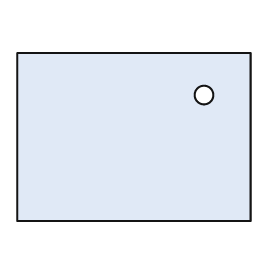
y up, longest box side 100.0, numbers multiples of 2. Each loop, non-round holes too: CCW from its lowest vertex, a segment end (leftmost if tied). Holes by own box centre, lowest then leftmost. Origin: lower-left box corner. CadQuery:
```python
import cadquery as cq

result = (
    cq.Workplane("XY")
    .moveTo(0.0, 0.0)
    .lineTo(100.0, 0.0)
    .lineTo(100.0, 72.0)
    .lineTo(0.0, 72.0)
    .close()
    .moveTo(80.0, 54.0)
    .circle(4.0)
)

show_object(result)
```